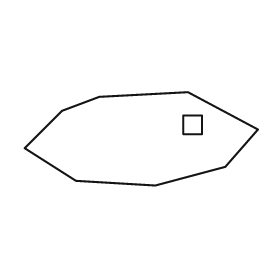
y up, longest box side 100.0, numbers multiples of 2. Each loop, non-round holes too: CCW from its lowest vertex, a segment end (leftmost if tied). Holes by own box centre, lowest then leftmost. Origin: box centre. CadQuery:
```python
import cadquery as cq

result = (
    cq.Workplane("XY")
    .moveTo(6.0, -20.0)
    .lineTo(36.0, -12.0)
    .lineTo(50.0, 4.0)
    .lineTo(20.0, 20.0)
    .lineTo(-18.0, 18.0)
    .lineTo(-34.0, 12.0)
    .lineTo(-50.0, -4.0)
    .lineTo(-28.0, -18.0)
    .close()
    .moveTo(18.0, 2.0)
    .lineTo(26.0, 2.0)
    .lineTo(26.0, 10.0)
    .lineTo(18.0, 10.0)
    .close()
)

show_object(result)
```